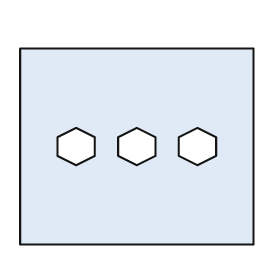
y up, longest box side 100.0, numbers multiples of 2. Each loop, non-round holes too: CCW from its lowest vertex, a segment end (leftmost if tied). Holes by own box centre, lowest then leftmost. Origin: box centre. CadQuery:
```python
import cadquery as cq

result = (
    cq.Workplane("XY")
    .moveTo(-50.0, -42.0)
    .lineTo(50.0, -42.0)
    .lineTo(50.0, 42.0)
    .lineTo(-50.0, 42.0)
    .close()
    .moveTo(-26.0, -8.0)
    .lineTo(-18.0, -4.0)
    .lineTo(-18.0, 4.0)
    .lineTo(-26.0, 8.0)
    .lineTo(-34.0, 4.0)
    .lineTo(-34.0, -4.0)
    .close()
    .moveTo(0.0, -8.0)
    .lineTo(8.0, -4.0)
    .lineTo(8.0, 4.0)
    .lineTo(0.0, 8.0)
    .lineTo(-8.0, 4.0)
    .lineTo(-8.0, -4.0)
    .close()
    .moveTo(26.0, -8.0)
    .lineTo(34.0, -4.0)
    .lineTo(34.0, 4.0)
    .lineTo(26.0, 8.0)
    .lineTo(18.0, 4.0)
    .lineTo(18.0, -4.0)
    .close()
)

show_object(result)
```